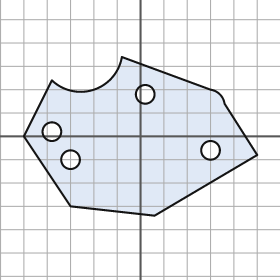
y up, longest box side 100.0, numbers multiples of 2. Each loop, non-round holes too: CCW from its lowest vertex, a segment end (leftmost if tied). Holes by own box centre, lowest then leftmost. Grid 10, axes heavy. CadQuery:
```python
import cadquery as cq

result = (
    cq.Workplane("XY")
    .moveTo(6.0, -34.0)
    .lineTo(50.0, -8.0)
    .lineTo(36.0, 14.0)
    .threePointArc((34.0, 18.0), (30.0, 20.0))
    .lineTo(-8.0, 34.0)
    .threePointArc((-20.0, 20.0), (-38.0, 24.0))
    .lineTo(-50.0, 0.0)
    .lineTo(-30.0, -30.0)
    .close()
    .moveTo(-30.0, -10.0)
    .circle(4.0)
    .moveTo(30.0, -6.0)
    .circle(4.0)
    .moveTo(-38.0, 2.0)
    .circle(4.0)
    .moveTo(2.0, 18.0)
    .circle(4.0)
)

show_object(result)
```